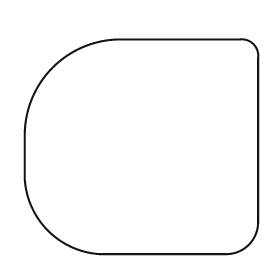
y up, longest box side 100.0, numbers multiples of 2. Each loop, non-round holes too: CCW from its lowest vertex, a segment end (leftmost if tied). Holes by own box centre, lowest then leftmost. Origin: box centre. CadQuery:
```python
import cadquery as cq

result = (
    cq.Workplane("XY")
    .moveTo(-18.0, -46.0)
    .lineTo(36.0, -46.0)
    .threePointArc((46.0, -42.0), (50.0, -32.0))
    .lineTo(50.0, 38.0)
    .threePointArc((48.0, 44.0), (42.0, 46.0))
    .lineTo(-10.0, 46.0)
    .threePointArc((-38.0, 34.0), (-50.0, 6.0))
    .lineTo(-50.0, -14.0)
    .threePointArc((-40.0, -36.0), (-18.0, -46.0))
    .close()
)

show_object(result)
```